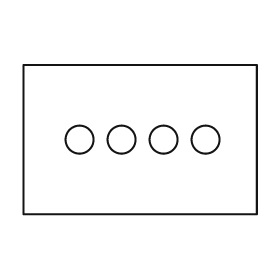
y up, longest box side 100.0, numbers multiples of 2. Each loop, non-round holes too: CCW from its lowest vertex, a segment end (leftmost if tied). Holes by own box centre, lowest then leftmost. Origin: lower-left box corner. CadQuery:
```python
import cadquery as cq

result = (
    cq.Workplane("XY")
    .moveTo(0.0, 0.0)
    .lineTo(100.0, 0.0)
    .lineTo(100.0, 64.0)
    .lineTo(0.0, 64.0)
    .close()
    .moveTo(24.0, 32.0)
    .circle(6.0)
    .moveTo(42.0, 32.0)
    .circle(6.0)
    .moveTo(60.0, 32.0)
    .circle(6.0)
    .moveTo(78.0, 32.0)
    .circle(6.0)
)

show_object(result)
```